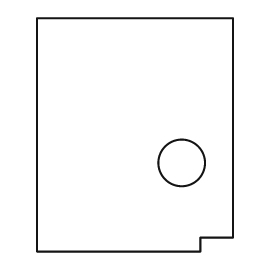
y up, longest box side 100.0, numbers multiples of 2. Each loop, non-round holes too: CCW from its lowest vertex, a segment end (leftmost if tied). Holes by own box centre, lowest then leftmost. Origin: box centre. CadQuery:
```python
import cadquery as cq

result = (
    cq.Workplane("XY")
    .moveTo(-42.0, -50.0)
    .lineTo(28.0, -50.0)
    .lineTo(28.0, -44.0)
    .lineTo(42.0, -44.0)
    .lineTo(42.0, 50.0)
    .lineTo(-42.0, 50.0)
    .close()
    .moveTo(20.0, -12.0)
    .circle(10.0)
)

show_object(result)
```